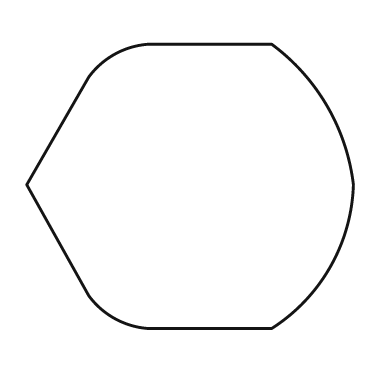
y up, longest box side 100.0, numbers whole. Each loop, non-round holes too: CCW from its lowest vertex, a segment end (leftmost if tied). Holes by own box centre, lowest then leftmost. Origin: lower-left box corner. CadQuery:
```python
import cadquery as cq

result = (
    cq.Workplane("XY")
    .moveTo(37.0, 0.0)
    .lineTo(75.0, 0.0)
    .threePointArc((93.0, 19.0), (100.0, 44.0))
    .threePointArc((92.0, 68.0), (75.0, 87.0))
    .lineTo(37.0, 87.0)
    .threePointArc((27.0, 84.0), (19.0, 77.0))
    .lineTo(0.0, 44.0)
    .lineTo(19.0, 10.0)
    .threePointArc((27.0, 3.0), (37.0, 0.0))
    .close()
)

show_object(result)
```